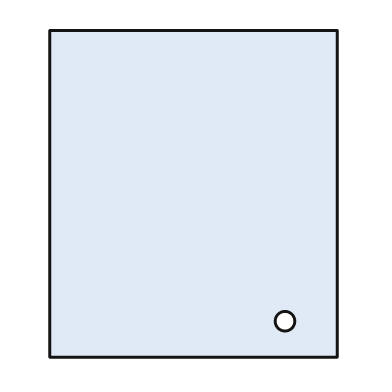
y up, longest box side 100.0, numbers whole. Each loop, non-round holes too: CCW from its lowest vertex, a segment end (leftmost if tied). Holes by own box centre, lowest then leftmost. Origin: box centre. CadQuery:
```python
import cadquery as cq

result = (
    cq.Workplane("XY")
    .moveTo(-44.0, -50.0)
    .lineTo(44.0, -50.0)
    .lineTo(44.0, 50.0)
    .lineTo(-44.0, 50.0)
    .close()
    .moveTo(28.0, -39.0)
    .circle(3.0)
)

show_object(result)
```